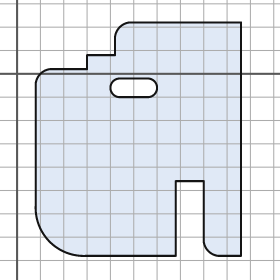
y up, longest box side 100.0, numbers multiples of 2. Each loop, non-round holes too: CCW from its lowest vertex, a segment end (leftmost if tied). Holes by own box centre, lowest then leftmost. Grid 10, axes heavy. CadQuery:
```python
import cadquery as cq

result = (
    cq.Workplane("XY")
    .moveTo(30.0, -78.0)
    .lineTo(68.0, -78.0)
    .lineTo(68.0, -46.0)
    .lineTo(80.0, -46.0)
    .lineTo(80.0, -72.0)
    .threePointArc((82.0, -76.0), (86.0, -78.0))
    .lineTo(96.0, -78.0)
    .lineTo(96.0, 22.0)
    .lineTo(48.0, 22.0)
    .threePointArc((44.0, 20.0), (42.0, 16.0))
    .lineTo(42.0, 8.0)
    .lineTo(30.0, 8.0)
    .lineTo(30.0, 2.0)
    .lineTo(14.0, 2.0)
    .threePointArc((10.0, 0.0), (8.0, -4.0))
    .lineTo(8.0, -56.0)
    .threePointArc((14.0, -72.0), (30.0, -78.0))
    .close()
    .moveTo(44.0, -10.0)
    .lineTo(56.0, -10.0)
    .threePointArc((60.0, -6.0), (56.0, -2.0))
    .lineTo(44.0, -2.0)
    .threePointArc((40.0, -6.0), (44.0, -10.0))
    .close()
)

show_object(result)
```